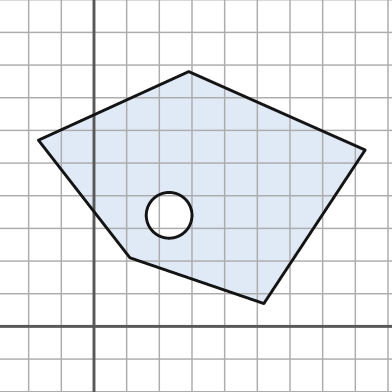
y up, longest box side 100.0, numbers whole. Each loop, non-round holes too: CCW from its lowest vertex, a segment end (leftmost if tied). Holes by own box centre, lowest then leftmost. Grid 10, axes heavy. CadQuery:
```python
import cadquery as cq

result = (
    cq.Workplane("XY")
    .moveTo(52.0, 7.0)
    .lineTo(83.0, 54.0)
    .lineTo(29.0, 78.0)
    .lineTo(-17.0, 57.0)
    .lineTo(11.0, 21.0)
    .close()
    .moveTo(23.0, 34.0)
    .circle(7.0)
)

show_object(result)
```